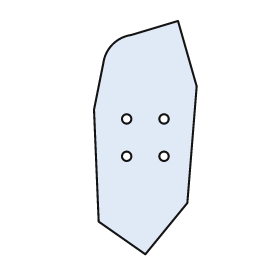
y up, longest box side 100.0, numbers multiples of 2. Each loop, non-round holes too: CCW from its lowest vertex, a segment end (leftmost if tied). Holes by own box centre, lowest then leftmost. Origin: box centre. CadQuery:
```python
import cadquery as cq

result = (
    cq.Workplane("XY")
    .moveTo(0.0, -50.0)
    .lineTo(18.0, -28.0)
    .lineTo(22.0, 22.0)
    .lineTo(14.0, 50.0)
    .lineTo(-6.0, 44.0)
    .threePointArc((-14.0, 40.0), (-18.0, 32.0))
    .lineTo(-22.0, 12.0)
    .lineTo(-20.0, -36.0)
    .close()
    .moveTo(-8.0, -8.0)
    .circle(2.0)
    .moveTo(8.0, -8.0)
    .circle(2.0)
    .moveTo(-8.0, 8.0)
    .circle(2.0)
    .moveTo(8.0, 8.0)
    .circle(2.0)
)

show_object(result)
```